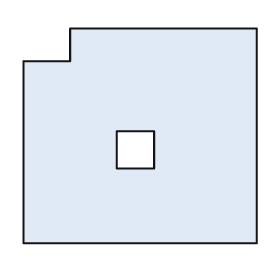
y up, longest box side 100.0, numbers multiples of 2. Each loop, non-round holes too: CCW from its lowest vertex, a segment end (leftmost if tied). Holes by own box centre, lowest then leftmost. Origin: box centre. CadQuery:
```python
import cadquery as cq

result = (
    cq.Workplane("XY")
    .moveTo(-50.0, -46.0)
    .lineTo(50.0, -46.0)
    .lineTo(50.0, 46.0)
    .lineTo(-30.0, 46.0)
    .lineTo(-30.0, 32.0)
    .lineTo(-50.0, 32.0)
    .close()
    .moveTo(-10.0, -14.0)
    .lineTo(6.0, -14.0)
    .lineTo(6.0, 2.0)
    .lineTo(-10.0, 2.0)
    .close()
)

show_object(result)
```